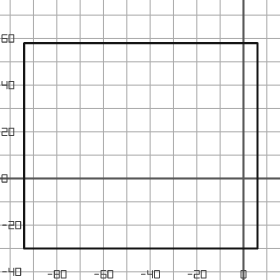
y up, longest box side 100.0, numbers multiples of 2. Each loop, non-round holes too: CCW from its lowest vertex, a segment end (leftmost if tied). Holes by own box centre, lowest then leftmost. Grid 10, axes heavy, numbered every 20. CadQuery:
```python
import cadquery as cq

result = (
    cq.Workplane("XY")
    .moveTo(-94.0, -30.0)
    .lineTo(6.0, -30.0)
    .lineTo(6.0, 58.0)
    .lineTo(-94.0, 58.0)
    .close()
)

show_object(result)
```